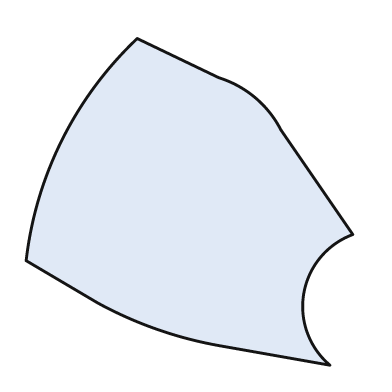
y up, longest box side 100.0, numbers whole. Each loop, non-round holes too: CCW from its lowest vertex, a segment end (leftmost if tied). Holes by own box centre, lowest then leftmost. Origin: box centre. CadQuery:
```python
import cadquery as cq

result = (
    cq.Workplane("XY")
    .moveTo(43.0, -50.0)
    .threePointArc((35.0, -28.0), (50.0, -10.0))
    .lineTo(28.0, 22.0)
    .threePointArc((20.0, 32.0), (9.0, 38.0))
    .lineTo(-16.0, 50.0)
    .threePointArc((-39.0, 19.0), (-50.0, -18.0))
    .lineTo(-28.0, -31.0)
    .threePointArc((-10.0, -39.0), (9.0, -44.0))
    .close()
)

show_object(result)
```